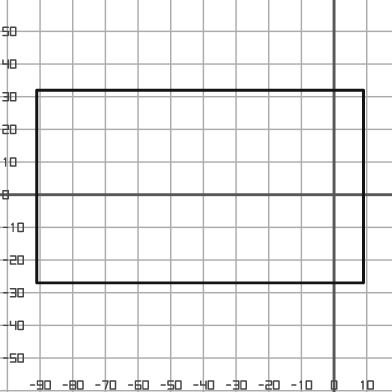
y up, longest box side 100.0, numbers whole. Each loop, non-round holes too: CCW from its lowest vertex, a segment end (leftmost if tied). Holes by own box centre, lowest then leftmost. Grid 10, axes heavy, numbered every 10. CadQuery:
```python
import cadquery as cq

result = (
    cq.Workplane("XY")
    .moveTo(-91.0, -27.0)
    .lineTo(9.0, -27.0)
    .lineTo(9.0, 32.0)
    .lineTo(-91.0, 32.0)
    .close()
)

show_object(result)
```